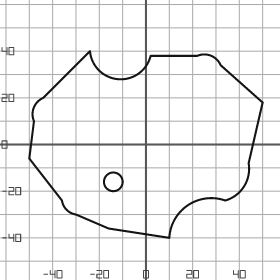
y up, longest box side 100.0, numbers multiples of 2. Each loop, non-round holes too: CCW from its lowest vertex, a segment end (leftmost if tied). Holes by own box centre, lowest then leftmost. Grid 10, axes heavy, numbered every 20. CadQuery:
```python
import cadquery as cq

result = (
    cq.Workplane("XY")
    .moveTo(10.0, -40.0)
    .threePointArc((18.0, -26.0), (34.0, -24.0))
    .threePointArc((42.0, -18.0), (44.0, -8.0))
    .lineTo(50.0, 18.0)
    .lineTo(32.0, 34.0)
    .threePointArc((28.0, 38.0), (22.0, 38.0))
    .lineTo(2.0, 38.0)
    .threePointArc((-12.0, 28.0), (-24.0, 40.0))
    .lineTo(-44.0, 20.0)
    .threePointArc((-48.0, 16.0), (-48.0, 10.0))
    .lineTo(-50.0, -6.0)
    .lineTo(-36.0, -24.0)
    .threePointArc((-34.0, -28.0), (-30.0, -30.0))
    .lineTo(-16.0, -36.0)
    .close()
    .moveTo(-14.0, -16.0)
    .circle(4.0)
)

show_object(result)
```